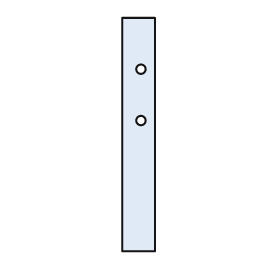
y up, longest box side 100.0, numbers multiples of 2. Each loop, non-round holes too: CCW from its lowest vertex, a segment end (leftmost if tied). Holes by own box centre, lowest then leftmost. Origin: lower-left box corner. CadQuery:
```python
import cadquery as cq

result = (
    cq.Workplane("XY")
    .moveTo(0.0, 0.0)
    .lineTo(14.0, 0.0)
    .lineTo(14.0, 100.0)
    .lineTo(0.0, 100.0)
    .close()
    .moveTo(8.0, 56.0)
    .circle(2.0)
    .moveTo(8.0, 78.0)
    .circle(2.0)
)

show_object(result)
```